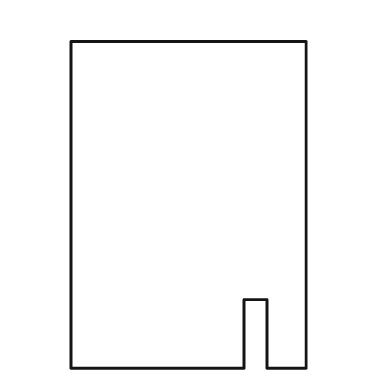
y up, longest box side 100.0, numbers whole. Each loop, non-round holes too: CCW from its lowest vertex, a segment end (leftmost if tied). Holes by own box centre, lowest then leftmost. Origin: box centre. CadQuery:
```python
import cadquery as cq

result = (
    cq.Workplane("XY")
    .moveTo(-36.0, -50.0)
    .lineTo(17.0, -50.0)
    .lineTo(17.0, -29.0)
    .lineTo(24.0, -29.0)
    .lineTo(24.0, -50.0)
    .lineTo(36.0, -50.0)
    .lineTo(36.0, 50.0)
    .lineTo(-36.0, 50.0)
    .close()
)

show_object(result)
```